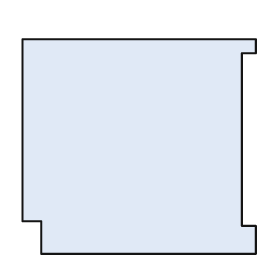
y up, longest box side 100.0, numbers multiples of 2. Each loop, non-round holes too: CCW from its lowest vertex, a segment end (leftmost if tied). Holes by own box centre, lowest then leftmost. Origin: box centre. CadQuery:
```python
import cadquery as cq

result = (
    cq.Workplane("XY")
    .moveTo(-42.0, -46.0)
    .lineTo(50.0, -46.0)
    .lineTo(50.0, -34.0)
    .lineTo(44.0, -34.0)
    .lineTo(44.0, 40.0)
    .lineTo(50.0, 40.0)
    .lineTo(50.0, 46.0)
    .lineTo(-50.0, 46.0)
    .lineTo(-50.0, -32.0)
    .lineTo(-42.0, -32.0)
    .close()
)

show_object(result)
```